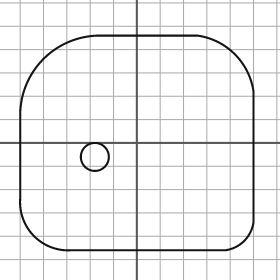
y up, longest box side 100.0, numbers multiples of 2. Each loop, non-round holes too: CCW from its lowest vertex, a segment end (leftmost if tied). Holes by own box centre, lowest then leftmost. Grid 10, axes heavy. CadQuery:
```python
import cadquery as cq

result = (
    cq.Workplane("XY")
    .moveTo(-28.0, -46.0)
    .lineTo(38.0, -46.0)
    .threePointArc((46.0, -42.0), (50.0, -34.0))
    .lineTo(50.0, 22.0)
    .threePointArc((42.0, 38.0), (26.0, 46.0))
    .lineTo(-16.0, 46.0)
    .threePointArc((-40.0, 36.0), (-50.0, 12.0))
    .lineTo(-50.0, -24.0)
    .threePointArc((-44.0, -40.0), (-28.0, -46.0))
    .close()
    .moveTo(-18.0, -6.0)
    .circle(6.0)
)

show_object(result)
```